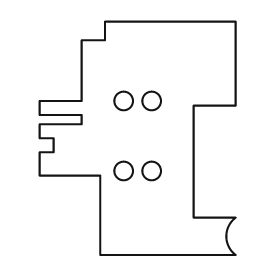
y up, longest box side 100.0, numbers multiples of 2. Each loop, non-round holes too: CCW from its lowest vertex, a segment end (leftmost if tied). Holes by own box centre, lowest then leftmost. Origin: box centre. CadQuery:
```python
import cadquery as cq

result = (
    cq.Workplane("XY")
    .moveTo(-16.0, -50.0)
    .lineTo(42.0, -50.0)
    .threePointArc((38.0, -42.0), (42.0, -34.0))
    .lineTo(24.0, -34.0)
    .lineTo(24.0, 14.0)
    .lineTo(42.0, 14.0)
    .lineTo(42.0, 50.0)
    .lineTo(-14.0, 50.0)
    .lineTo(-14.0, 42.0)
    .lineTo(-24.0, 42.0)
    .lineTo(-24.0, 16.0)
    .lineTo(-42.0, 16.0)
    .lineTo(-42.0, 10.0)
    .lineTo(-24.0, 10.0)
    .lineTo(-24.0, 6.0)
    .lineTo(-42.0, 6.0)
    .lineTo(-42.0, 0.0)
    .lineTo(-36.0, 0.0)
    .lineTo(-36.0, -6.0)
    .lineTo(-42.0, -6.0)
    .lineTo(-42.0, -16.0)
    .lineTo(-16.0, -16.0)
    .close()
    .moveTo(-6.0, -14.0)
    .circle(4.0)
    .moveTo(6.0, -14.0)
    .circle(4.0)
    .moveTo(-6.0, 16.0)
    .circle(4.0)
    .moveTo(6.0, 16.0)
    .circle(4.0)
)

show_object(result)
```